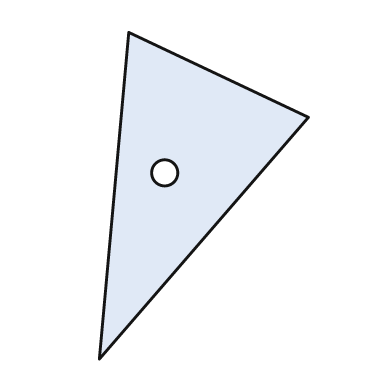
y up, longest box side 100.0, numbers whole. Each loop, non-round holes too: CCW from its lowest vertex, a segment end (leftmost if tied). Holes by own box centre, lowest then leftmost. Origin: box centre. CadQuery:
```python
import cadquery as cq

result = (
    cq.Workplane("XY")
    .moveTo(-32.0, -50.0)
    .lineTo(32.0, 24.0)
    .lineTo(-23.0, 50.0)
    .close()
    .moveTo(-12.0, 7.0)
    .circle(4.0)
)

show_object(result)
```